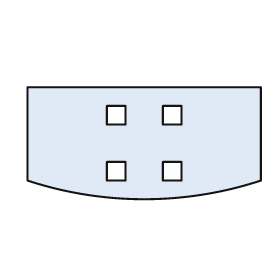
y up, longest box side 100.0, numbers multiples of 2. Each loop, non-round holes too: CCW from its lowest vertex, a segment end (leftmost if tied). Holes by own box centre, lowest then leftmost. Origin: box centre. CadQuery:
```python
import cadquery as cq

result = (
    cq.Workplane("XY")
    .moveTo(-50.0, -16.0)
    .threePointArc((0.0, -24.0), (50.0, -16.0))
    .lineTo(50.0, 24.0)
    .lineTo(-50.0, 24.0)
    .close()
    .moveTo(-16.0, -16.0)
    .lineTo(-8.0, -16.0)
    .lineTo(-8.0, -8.0)
    .lineTo(-16.0, -8.0)
    .close()
    .moveTo(8.0, -16.0)
    .lineTo(16.0, -16.0)
    .lineTo(16.0, -8.0)
    .lineTo(8.0, -8.0)
    .close()
    .moveTo(-16.0, 8.0)
    .lineTo(-8.0, 8.0)
    .lineTo(-8.0, 16.0)
    .lineTo(-16.0, 16.0)
    .close()
    .moveTo(8.0, 8.0)
    .lineTo(16.0, 8.0)
    .lineTo(16.0, 16.0)
    .lineTo(8.0, 16.0)
    .close()
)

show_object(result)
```